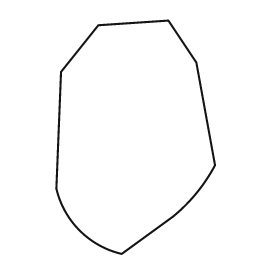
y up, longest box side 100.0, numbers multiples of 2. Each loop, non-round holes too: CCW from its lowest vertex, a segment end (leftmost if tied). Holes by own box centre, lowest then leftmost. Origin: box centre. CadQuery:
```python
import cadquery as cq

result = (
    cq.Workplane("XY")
    .moveTo(-6.0, -50.0)
    .lineTo(16.0, -34.0)
    .threePointArc((26.0, -24.0), (34.0, -12.0))
    .lineTo(26.0, 32.0)
    .lineTo(14.0, 50.0)
    .lineTo(-16.0, 48.0)
    .lineTo(-32.0, 28.0)
    .lineTo(-34.0, -22.0)
    .threePointArc((-24.0, -40.0), (-6.0, -50.0))
    .close()
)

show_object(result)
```